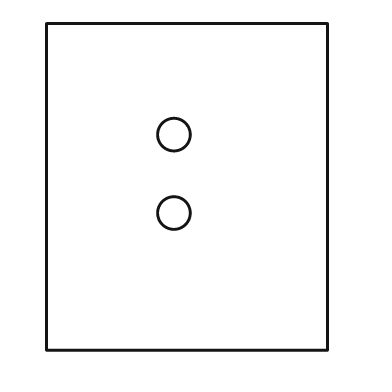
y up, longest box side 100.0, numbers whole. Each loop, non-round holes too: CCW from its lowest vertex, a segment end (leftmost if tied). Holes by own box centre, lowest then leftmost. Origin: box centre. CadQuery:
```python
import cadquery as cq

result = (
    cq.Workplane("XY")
    .moveTo(-43.0, -50.0)
    .lineTo(43.0, -50.0)
    .lineTo(43.0, 50.0)
    .lineTo(-43.0, 50.0)
    .close()
    .moveTo(-4.0, -8.0)
    .circle(5.0)
    .moveTo(-4.0, 16.0)
    .circle(5.0)
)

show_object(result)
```